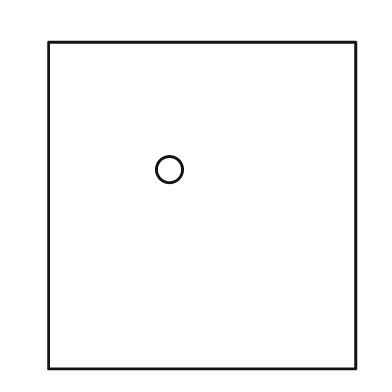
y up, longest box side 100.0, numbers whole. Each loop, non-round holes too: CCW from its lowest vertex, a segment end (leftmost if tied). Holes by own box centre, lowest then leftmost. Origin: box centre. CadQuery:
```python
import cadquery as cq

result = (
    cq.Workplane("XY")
    .moveTo(-47.0, -50.0)
    .lineTo(47.0, -50.0)
    .lineTo(47.0, 50.0)
    .lineTo(-47.0, 50.0)
    .close()
    .moveTo(-10.0, 11.0)
    .circle(4.0)
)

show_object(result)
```